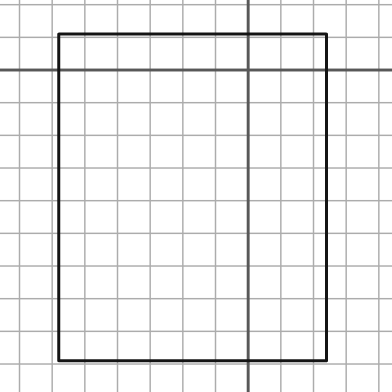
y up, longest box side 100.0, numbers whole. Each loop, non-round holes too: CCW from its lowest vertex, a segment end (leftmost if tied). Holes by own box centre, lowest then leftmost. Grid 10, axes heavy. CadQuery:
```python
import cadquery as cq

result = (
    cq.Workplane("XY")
    .moveTo(-58.0, -89.0)
    .lineTo(24.0, -89.0)
    .lineTo(24.0, 11.0)
    .lineTo(-58.0, 11.0)
    .close()
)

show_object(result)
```